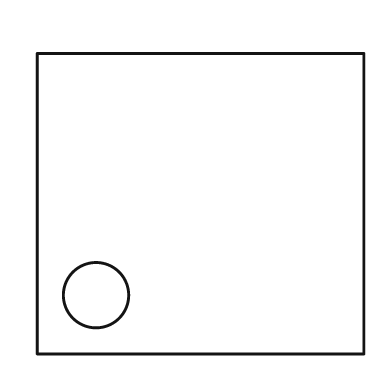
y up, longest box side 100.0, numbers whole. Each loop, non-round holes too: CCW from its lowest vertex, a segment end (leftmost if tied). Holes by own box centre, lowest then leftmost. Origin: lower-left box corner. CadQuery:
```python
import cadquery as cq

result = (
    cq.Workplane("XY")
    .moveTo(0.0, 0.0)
    .lineTo(100.0, 0.0)
    .lineTo(100.0, 92.0)
    .lineTo(0.0, 92.0)
    .close()
    .moveTo(18.0, 18.0)
    .circle(10.0)
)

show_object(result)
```